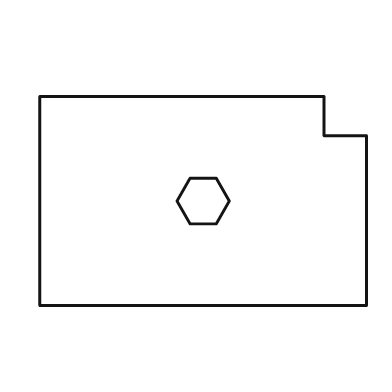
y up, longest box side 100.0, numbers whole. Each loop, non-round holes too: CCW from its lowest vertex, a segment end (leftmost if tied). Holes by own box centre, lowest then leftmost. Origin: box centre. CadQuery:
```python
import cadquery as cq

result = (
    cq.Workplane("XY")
    .moveTo(-50.0, -32.0)
    .lineTo(50.0, -32.0)
    .lineTo(50.0, 20.0)
    .lineTo(37.0, 20.0)
    .lineTo(37.0, 32.0)
    .lineTo(-50.0, 32.0)
    .close()
    .moveTo(-4.0, -7.0)
    .lineTo(4.0, -7.0)
    .lineTo(8.0, 0.0)
    .lineTo(4.0, 7.0)
    .lineTo(-4.0, 7.0)
    .lineTo(-8.0, 0.0)
    .close()
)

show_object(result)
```